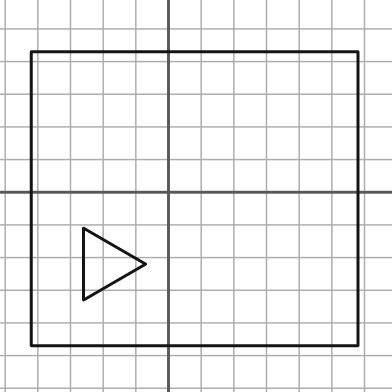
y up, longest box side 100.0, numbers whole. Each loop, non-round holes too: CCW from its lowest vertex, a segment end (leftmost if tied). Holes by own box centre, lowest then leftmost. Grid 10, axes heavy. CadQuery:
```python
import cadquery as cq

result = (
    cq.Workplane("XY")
    .moveTo(-42.0, -47.0)
    .lineTo(58.0, -47.0)
    .lineTo(58.0, 43.0)
    .lineTo(-42.0, 43.0)
    .close()
    .moveTo(-26.0, -33.0)
    .lineTo(-7.0, -22.0)
    .lineTo(-26.0, -11.0)
    .close()
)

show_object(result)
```